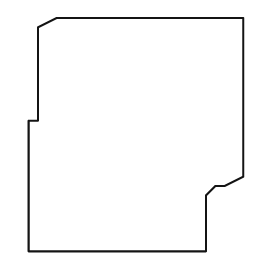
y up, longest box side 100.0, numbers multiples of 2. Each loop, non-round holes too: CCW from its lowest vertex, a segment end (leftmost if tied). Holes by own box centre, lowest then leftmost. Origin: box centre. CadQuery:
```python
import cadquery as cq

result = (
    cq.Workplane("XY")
    .moveTo(-46.0, -50.0)
    .lineTo(30.0, -50.0)
    .lineTo(30.0, -26.0)
    .lineTo(34.0, -22.0)
    .lineTo(38.0, -22.0)
    .lineTo(46.0, -18.0)
    .lineTo(46.0, 50.0)
    .lineTo(-34.0, 50.0)
    .lineTo(-42.0, 46.0)
    .lineTo(-42.0, 6.0)
    .lineTo(-46.0, 6.0)
    .close()
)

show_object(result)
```